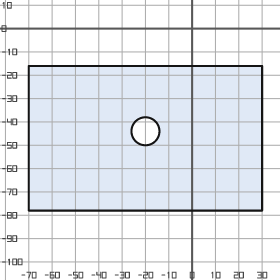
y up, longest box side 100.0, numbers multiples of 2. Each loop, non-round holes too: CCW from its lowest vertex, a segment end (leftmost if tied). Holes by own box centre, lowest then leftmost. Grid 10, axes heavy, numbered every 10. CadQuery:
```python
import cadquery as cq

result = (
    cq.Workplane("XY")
    .moveTo(-70.0, -78.0)
    .lineTo(30.0, -78.0)
    .lineTo(30.0, -16.0)
    .lineTo(-70.0, -16.0)
    .close()
    .moveTo(-20.0, -44.0)
    .circle(6.0)
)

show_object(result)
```